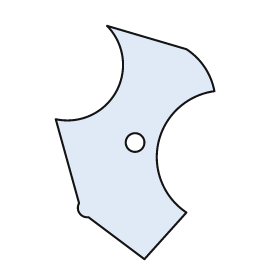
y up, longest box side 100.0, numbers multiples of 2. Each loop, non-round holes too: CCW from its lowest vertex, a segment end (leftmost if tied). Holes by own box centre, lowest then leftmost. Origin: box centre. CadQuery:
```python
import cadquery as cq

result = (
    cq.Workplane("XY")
    .moveTo(4.0, -50.0)
    .lineTo(22.0, -30.0)
    .threePointArc((10.0, 0.0), (34.0, 22.0))
    .threePointArc((30.0, 32.0), (22.0, 40.0))
    .lineTo(-12.0, 50.0)
    .threePointArc((-8.0, 22.0), (-34.0, 10.0))
    .lineTo(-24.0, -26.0)
    .threePointArc((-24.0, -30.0), (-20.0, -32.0))
    .close()
    .moveTo(0.0, 0.0)
    .circle(4.0)
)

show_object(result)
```